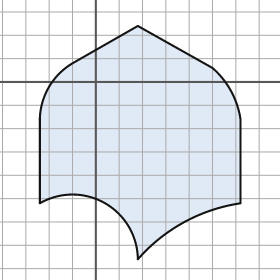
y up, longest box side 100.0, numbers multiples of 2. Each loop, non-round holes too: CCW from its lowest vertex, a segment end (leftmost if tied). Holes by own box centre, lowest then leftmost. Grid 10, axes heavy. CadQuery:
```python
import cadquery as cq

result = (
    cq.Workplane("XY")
    .moveTo(18.0, -76.0)
    .threePointArc((38.0, -60.0), (62.0, -52.0))
    .lineTo(62.0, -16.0)
    .threePointArc((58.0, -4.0), (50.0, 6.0))
    .lineTo(18.0, 24.0)
    .lineTo(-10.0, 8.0)
    .threePointArc((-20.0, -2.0), (-24.0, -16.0))
    .lineTo(-24.0, -52.0)
    .threePointArc((4.0, -52.0), (18.0, -76.0))
    .close()
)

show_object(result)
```